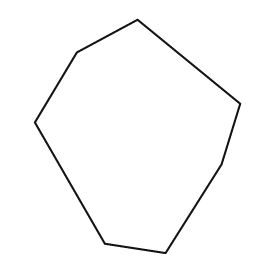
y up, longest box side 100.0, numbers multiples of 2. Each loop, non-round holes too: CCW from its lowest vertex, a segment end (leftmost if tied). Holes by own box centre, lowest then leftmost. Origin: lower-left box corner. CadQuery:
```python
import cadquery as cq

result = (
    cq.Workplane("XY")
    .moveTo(56.0, 0.0)
    .lineTo(80.0, 38.0)
    .lineTo(88.0, 64.0)
    .lineTo(44.0, 100.0)
    .lineTo(18.0, 86.0)
    .lineTo(0.0, 56.0)
    .lineTo(30.0, 4.0)
    .close()
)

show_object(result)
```